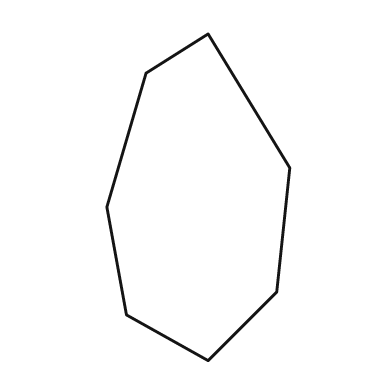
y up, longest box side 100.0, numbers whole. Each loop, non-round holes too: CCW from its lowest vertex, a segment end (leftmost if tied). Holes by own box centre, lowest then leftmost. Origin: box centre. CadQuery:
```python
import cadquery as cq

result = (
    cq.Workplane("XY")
    .moveTo(3.0, -50.0)
    .lineTo(24.0, -29.0)
    .lineTo(28.0, 9.0)
    .lineTo(3.0, 50.0)
    .lineTo(-16.0, 38.0)
    .lineTo(-28.0, -3.0)
    .lineTo(-22.0, -36.0)
    .close()
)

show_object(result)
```